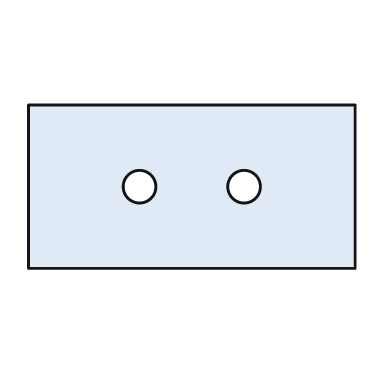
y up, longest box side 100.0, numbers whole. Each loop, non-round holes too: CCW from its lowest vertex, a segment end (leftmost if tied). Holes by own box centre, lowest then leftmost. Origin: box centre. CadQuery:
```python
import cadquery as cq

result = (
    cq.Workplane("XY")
    .moveTo(-50.0, -25.0)
    .lineTo(50.0, -25.0)
    .lineTo(50.0, 25.0)
    .lineTo(-50.0, 25.0)
    .close()
    .moveTo(-16.0, 0.0)
    .circle(5.0)
    .moveTo(16.0, 0.0)
    .circle(5.0)
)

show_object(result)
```